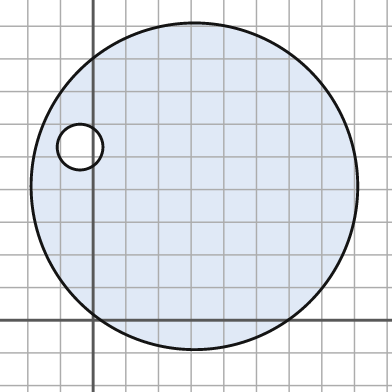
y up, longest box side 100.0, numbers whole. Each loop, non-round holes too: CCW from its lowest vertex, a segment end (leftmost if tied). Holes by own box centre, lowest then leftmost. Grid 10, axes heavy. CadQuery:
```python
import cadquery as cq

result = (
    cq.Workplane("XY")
    .moveTo(31.0, 41.0)
    .circle(50.0)
    .moveTo(-4.0, 53.0)
    .circle(7.0)
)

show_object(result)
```